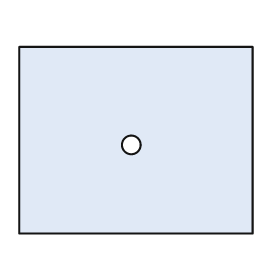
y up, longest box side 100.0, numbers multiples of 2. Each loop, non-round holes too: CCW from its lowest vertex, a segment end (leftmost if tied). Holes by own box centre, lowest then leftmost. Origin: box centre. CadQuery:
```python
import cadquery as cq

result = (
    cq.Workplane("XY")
    .moveTo(-50.0, -40.0)
    .lineTo(50.0, -40.0)
    .lineTo(50.0, 40.0)
    .lineTo(-50.0, 40.0)
    .close()
    .moveTo(-2.0, -2.0)
    .circle(4.0)
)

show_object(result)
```